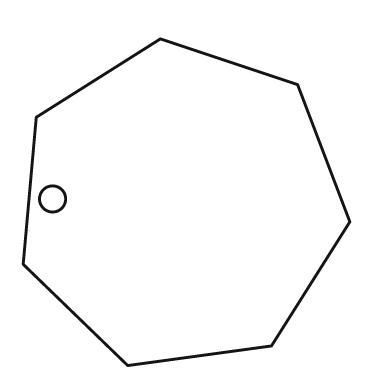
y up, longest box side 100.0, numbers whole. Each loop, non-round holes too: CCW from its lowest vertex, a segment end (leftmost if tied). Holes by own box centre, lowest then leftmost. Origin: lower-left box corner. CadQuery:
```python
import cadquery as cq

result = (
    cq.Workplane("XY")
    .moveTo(32.0, 0.0)
    .lineTo(76.0, 6.0)
    .lineTo(100.0, 44.0)
    .lineTo(84.0, 86.0)
    .lineTo(42.0, 100.0)
    .lineTo(4.0, 76.0)
    .lineTo(0.0, 31.0)
    .close()
    .moveTo(9.0, 51.0)
    .circle(4.0)
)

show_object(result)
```